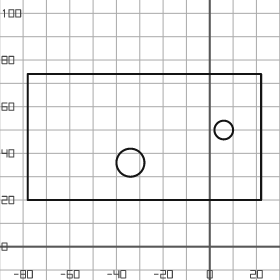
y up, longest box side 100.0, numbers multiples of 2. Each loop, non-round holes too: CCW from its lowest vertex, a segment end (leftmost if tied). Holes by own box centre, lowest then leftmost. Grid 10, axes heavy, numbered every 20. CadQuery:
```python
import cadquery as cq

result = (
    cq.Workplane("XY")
    .moveTo(-78.0, 20.0)
    .lineTo(22.0, 20.0)
    .lineTo(22.0, 74.0)
    .lineTo(-78.0, 74.0)
    .close()
    .moveTo(-34.0, 36.0)
    .circle(6.0)
    .moveTo(6.0, 50.0)
    .circle(4.0)
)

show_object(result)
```